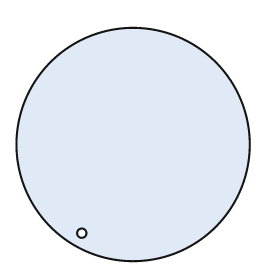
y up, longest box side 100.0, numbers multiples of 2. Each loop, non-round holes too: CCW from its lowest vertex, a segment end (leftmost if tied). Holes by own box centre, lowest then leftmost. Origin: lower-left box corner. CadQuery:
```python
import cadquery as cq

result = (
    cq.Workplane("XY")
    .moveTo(50.0, 50.0)
    .circle(50.0)
    .moveTo(28.0, 12.0)
    .circle(2.0)
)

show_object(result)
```